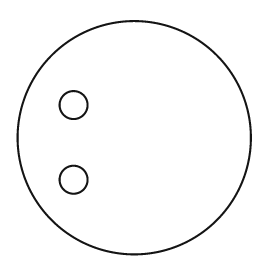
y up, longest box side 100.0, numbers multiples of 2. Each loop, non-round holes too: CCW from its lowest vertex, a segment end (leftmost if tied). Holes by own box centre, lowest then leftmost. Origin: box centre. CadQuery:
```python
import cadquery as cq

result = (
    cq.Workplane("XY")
    .moveTo(0.0, 0.0)
    .circle(50.0)
    .moveTo(-26.0, -18.0)
    .circle(6.0)
    .moveTo(-26.0, 14.0)
    .circle(6.0)
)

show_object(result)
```